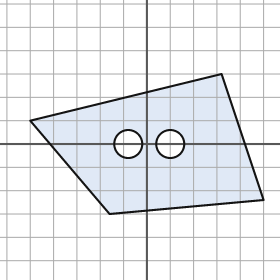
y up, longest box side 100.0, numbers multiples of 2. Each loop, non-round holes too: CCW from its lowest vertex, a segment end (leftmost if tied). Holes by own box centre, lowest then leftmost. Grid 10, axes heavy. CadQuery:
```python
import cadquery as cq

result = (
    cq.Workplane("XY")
    .moveTo(-16.0, -30.0)
    .lineTo(50.0, -24.0)
    .lineTo(32.0, 30.0)
    .lineTo(-50.0, 10.0)
    .close()
    .moveTo(-8.0, 0.0)
    .circle(6.0)
    .moveTo(10.0, 0.0)
    .circle(6.0)
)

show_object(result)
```